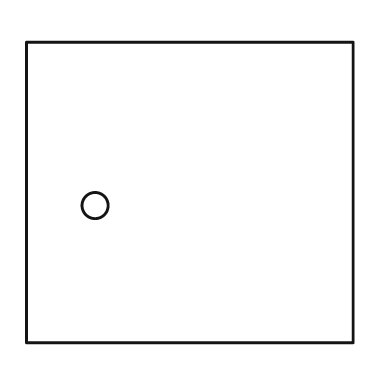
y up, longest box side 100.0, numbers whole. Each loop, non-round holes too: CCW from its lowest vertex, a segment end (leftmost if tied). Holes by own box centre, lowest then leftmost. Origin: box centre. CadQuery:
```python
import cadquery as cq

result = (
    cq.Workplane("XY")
    .moveTo(-50.0, -46.0)
    .lineTo(50.0, -46.0)
    .lineTo(50.0, 46.0)
    .lineTo(-50.0, 46.0)
    .close()
    .moveTo(-29.0, -4.0)
    .circle(4.0)
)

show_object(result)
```